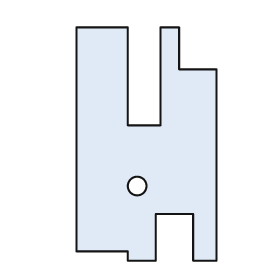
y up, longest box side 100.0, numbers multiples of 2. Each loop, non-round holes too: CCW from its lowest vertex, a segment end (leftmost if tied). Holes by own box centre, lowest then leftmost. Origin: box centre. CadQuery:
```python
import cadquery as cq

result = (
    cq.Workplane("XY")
    .moveTo(-8.0, -50.0)
    .lineTo(4.0, -50.0)
    .lineTo(4.0, -30.0)
    .lineTo(20.0, -30.0)
    .lineTo(20.0, -50.0)
    .lineTo(30.0, -50.0)
    .lineTo(30.0, 32.0)
    .lineTo(14.0, 32.0)
    .lineTo(14.0, 50.0)
    .lineTo(6.0, 50.0)
    .lineTo(6.0, 8.0)
    .lineTo(-8.0, 8.0)
    .lineTo(-8.0, 50.0)
    .lineTo(-30.0, 50.0)
    .lineTo(-30.0, -46.0)
    .lineTo(-8.0, -46.0)
    .close()
    .moveTo(-4.0, -18.0)
    .circle(4.0)
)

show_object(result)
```